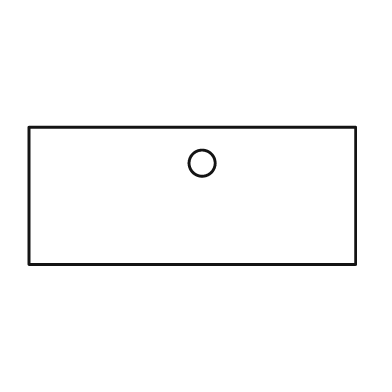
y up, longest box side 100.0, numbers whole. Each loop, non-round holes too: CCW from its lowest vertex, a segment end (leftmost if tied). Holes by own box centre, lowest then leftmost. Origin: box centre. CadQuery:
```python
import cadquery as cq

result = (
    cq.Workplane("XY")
    .moveTo(-50.0, -21.0)
    .lineTo(50.0, -21.0)
    .lineTo(50.0, 21.0)
    .lineTo(-50.0, 21.0)
    .close()
    .moveTo(3.0, 10.0)
    .circle(4.0)
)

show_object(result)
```